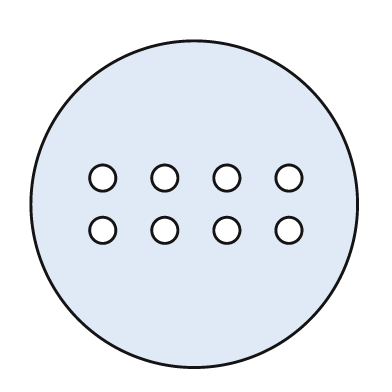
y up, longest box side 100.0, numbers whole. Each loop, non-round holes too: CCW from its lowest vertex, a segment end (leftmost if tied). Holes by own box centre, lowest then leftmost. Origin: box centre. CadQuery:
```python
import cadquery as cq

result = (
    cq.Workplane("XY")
    .moveTo(0.0, 0.0)
    .circle(50.0)
    .moveTo(-28.0, -8.0)
    .circle(4.0)
    .moveTo(-9.0, -8.0)
    .circle(4.0)
    .moveTo(10.0, -8.0)
    .circle(4.0)
    .moveTo(29.0, -8.0)
    .circle(4.0)
    .moveTo(-28.0, 8.0)
    .circle(4.0)
    .moveTo(-9.0, 8.0)
    .circle(4.0)
    .moveTo(10.0, 8.0)
    .circle(4.0)
    .moveTo(29.0, 8.0)
    .circle(4.0)
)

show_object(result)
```